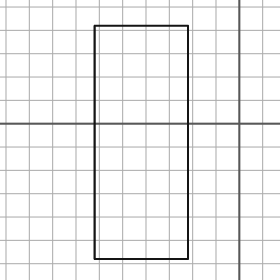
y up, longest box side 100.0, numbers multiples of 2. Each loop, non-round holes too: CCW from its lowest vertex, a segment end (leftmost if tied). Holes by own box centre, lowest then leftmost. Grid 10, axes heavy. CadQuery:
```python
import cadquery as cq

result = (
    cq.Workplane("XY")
    .moveTo(-62.0, -58.0)
    .lineTo(-22.0, -58.0)
    .lineTo(-22.0, 42.0)
    .lineTo(-62.0, 42.0)
    .close()
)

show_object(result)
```